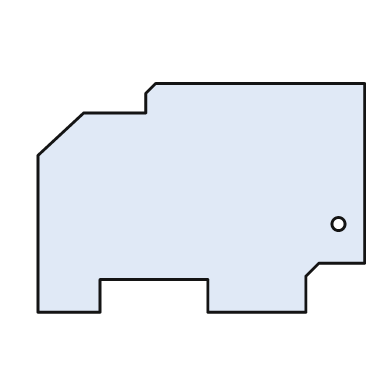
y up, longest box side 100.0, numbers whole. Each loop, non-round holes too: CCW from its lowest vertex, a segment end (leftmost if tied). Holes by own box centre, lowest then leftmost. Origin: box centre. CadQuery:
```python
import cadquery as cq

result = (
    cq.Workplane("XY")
    .moveTo(-50.0, -35.0)
    .lineTo(-31.0, -35.0)
    .lineTo(-31.0, -25.0)
    .lineTo(2.0, -25.0)
    .lineTo(2.0, -35.0)
    .lineTo(32.0, -35.0)
    .lineTo(32.0, -24.0)
    .lineTo(36.0, -20.0)
    .lineTo(50.0, -20.0)
    .lineTo(50.0, 35.0)
    .lineTo(-14.0, 35.0)
    .lineTo(-17.0, 32.0)
    .lineTo(-17.0, 26.0)
    .lineTo(-36.0, 26.0)
    .lineTo(-50.0, 13.0)
    .close()
    .moveTo(42.0, -8.0)
    .circle(2.0)
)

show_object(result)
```